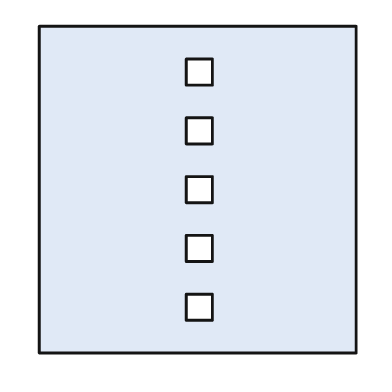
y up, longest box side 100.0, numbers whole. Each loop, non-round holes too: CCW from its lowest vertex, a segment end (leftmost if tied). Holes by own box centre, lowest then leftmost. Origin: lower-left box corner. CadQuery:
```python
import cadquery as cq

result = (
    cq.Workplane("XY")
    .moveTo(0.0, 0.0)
    .lineTo(97.0, 0.0)
    .lineTo(97.0, 100.0)
    .lineTo(0.0, 100.0)
    .close()
    .moveTo(45.0, 10.0)
    .lineTo(53.0, 10.0)
    .lineTo(53.0, 18.0)
    .lineTo(45.0, 18.0)
    .close()
    .moveTo(45.0, 28.0)
    .lineTo(53.0, 28.0)
    .lineTo(53.0, 36.0)
    .lineTo(45.0, 36.0)
    .close()
    .moveTo(45.0, 46.0)
    .lineTo(53.0, 46.0)
    .lineTo(53.0, 54.0)
    .lineTo(45.0, 54.0)
    .close()
    .moveTo(45.0, 64.0)
    .lineTo(53.0, 64.0)
    .lineTo(53.0, 72.0)
    .lineTo(45.0, 72.0)
    .close()
    .moveTo(45.0, 82.0)
    .lineTo(53.0, 82.0)
    .lineTo(53.0, 90.0)
    .lineTo(45.0, 90.0)
    .close()
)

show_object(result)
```